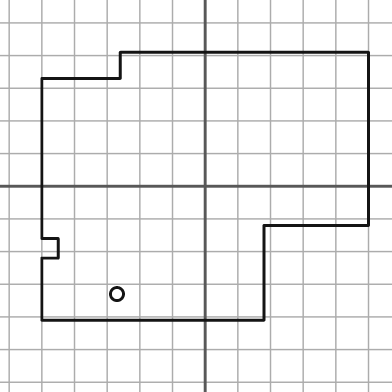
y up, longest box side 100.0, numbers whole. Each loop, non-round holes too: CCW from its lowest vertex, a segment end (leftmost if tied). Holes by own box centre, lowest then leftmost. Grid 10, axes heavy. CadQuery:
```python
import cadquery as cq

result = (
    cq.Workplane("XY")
    .moveTo(-50.0, -41.0)
    .lineTo(18.0, -41.0)
    .lineTo(18.0, -12.0)
    .lineTo(50.0, -12.0)
    .lineTo(50.0, 41.0)
    .lineTo(-26.0, 41.0)
    .lineTo(-26.0, 33.0)
    .lineTo(-50.0, 33.0)
    .lineTo(-50.0, -16.0)
    .lineTo(-45.0, -16.0)
    .lineTo(-45.0, -22.0)
    .lineTo(-50.0, -22.0)
    .close()
    .moveTo(-27.0, -33.0)
    .circle(2.0)
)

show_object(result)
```